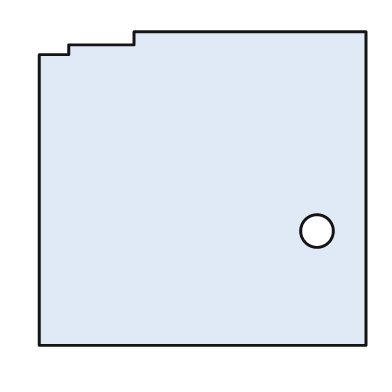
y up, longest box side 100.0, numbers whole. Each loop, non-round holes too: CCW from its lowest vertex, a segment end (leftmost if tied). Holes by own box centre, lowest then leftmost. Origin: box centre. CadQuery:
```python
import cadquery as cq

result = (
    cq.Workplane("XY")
    .moveTo(-50.0, -48.0)
    .lineTo(50.0, -48.0)
    .lineTo(50.0, 48.0)
    .lineTo(-21.0, 48.0)
    .lineTo(-21.0, 44.0)
    .lineTo(-41.0, 44.0)
    .lineTo(-41.0, 41.0)
    .lineTo(-50.0, 41.0)
    .close()
    .moveTo(35.0, -13.0)
    .circle(5.0)
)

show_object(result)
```